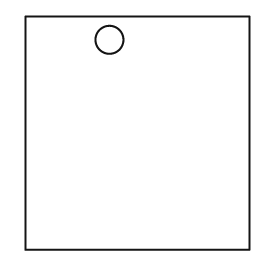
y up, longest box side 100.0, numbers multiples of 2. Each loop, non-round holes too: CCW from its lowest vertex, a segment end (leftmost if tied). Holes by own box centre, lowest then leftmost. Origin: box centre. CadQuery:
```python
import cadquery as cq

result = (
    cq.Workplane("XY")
    .moveTo(-48.0, -50.0)
    .lineTo(48.0, -50.0)
    .lineTo(48.0, 50.0)
    .lineTo(-48.0, 50.0)
    .close()
    .moveTo(-12.0, 40.0)
    .circle(6.0)
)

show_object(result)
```